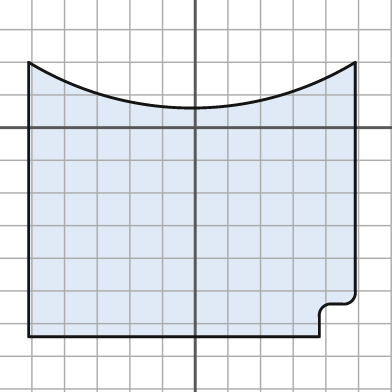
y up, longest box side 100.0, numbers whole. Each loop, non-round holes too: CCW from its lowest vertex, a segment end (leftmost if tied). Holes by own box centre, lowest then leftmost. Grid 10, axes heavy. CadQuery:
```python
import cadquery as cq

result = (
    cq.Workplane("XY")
    .moveTo(-51.0, -64.0)
    .lineTo(38.0, -64.0)
    .lineTo(38.0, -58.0)
    .threePointArc((39.0, -55.0), (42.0, -54.0))
    .lineTo(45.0, -54.0)
    .threePointArc((48.0, -53.0), (49.0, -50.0))
    .lineTo(49.0, 20.0)
    .threePointArc((-1.0, 6.0), (-51.0, 20.0))
    .close()
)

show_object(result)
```